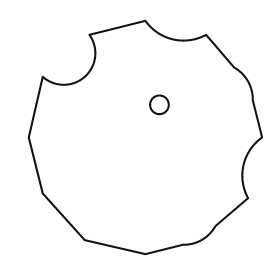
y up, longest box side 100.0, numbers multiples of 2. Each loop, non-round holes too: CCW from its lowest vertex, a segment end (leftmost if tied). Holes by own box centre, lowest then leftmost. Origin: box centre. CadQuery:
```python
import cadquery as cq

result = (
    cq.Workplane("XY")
    .moveTo(0.0, -50.0)
    .lineTo(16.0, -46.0)
    .threePointArc((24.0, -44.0), (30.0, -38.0))
    .lineTo(44.0, -26.0)
    .threePointArc((42.0, -12.0), (50.0, 0.0))
    .lineTo(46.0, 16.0)
    .threePointArc((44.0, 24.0), (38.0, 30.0))
    .lineTo(26.0, 44.0)
    .threePointArc((12.0, 42.0), (0.0, 50.0))
    .lineTo(-24.0, 44.0)
    .threePointArc((-26.0, 26.0), (-44.0, 26.0))
    .lineTo(-50.0, 0.0)
    .lineTo(-44.0, -24.0)
    .lineTo(-26.0, -44.0)
    .close()
    .moveTo(6.0, 14.0)
    .circle(4.0)
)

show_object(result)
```